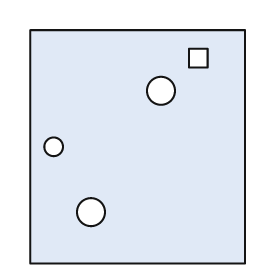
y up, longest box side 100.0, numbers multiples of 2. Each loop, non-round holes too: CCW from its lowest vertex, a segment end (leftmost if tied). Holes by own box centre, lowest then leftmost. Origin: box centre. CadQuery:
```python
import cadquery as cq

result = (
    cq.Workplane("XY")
    .moveTo(-46.0, -50.0)
    .lineTo(46.0, -50.0)
    .lineTo(46.0, 50.0)
    .lineTo(-46.0, 50.0)
    .close()
    .moveTo(-20.0, -28.0)
    .circle(6.0)
    .moveTo(-36.0, 0.0)
    .circle(4.0)
    .moveTo(10.0, 24.0)
    .circle(6.0)
    .moveTo(22.0, 34.0)
    .lineTo(30.0, 34.0)
    .lineTo(30.0, 42.0)
    .lineTo(22.0, 42.0)
    .close()
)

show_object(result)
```